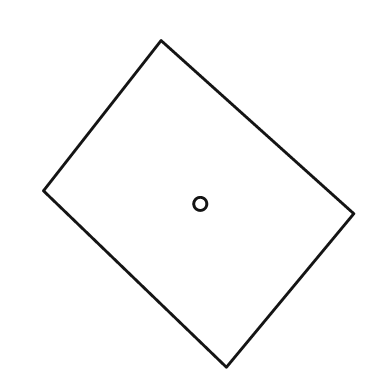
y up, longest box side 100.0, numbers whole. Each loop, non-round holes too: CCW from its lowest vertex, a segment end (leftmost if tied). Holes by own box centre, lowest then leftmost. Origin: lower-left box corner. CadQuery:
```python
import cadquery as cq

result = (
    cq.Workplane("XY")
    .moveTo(56.0, 0.0)
    .lineTo(95.0, 47.0)
    .lineTo(36.0, 100.0)
    .lineTo(0.0, 54.0)
    .close()
    .moveTo(48.0, 50.0)
    .circle(2.0)
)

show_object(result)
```